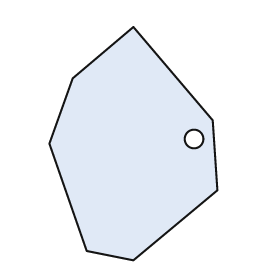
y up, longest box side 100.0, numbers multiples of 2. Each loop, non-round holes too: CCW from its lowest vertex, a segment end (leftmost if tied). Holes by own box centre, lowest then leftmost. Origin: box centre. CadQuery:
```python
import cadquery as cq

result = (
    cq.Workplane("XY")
    .moveTo(0.0, -50.0)
    .lineTo(36.0, -20.0)
    .lineTo(34.0, 10.0)
    .lineTo(0.0, 50.0)
    .lineTo(-26.0, 28.0)
    .lineTo(-36.0, 0.0)
    .lineTo(-20.0, -46.0)
    .close()
    .moveTo(26.0, 2.0)
    .circle(4.0)
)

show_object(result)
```